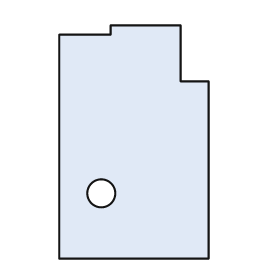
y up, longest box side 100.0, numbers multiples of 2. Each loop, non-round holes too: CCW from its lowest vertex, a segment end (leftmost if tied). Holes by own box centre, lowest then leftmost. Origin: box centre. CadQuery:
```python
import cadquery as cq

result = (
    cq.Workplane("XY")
    .moveTo(-32.0, -50.0)
    .lineTo(32.0, -50.0)
    .lineTo(32.0, 26.0)
    .lineTo(20.0, 26.0)
    .lineTo(20.0, 50.0)
    .lineTo(-10.0, 50.0)
    .lineTo(-10.0, 46.0)
    .lineTo(-32.0, 46.0)
    .close()
    .moveTo(-14.0, -22.0)
    .circle(6.0)
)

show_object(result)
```